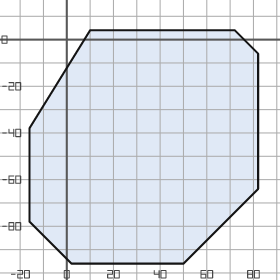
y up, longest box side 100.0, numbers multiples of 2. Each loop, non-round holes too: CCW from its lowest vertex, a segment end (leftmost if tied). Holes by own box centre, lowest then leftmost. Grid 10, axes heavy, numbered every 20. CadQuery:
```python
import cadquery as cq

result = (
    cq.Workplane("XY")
    .moveTo(2.0, -96.0)
    .lineTo(50.0, -96.0)
    .lineTo(82.0, -64.0)
    .lineTo(82.0, -6.0)
    .lineTo(72.0, 4.0)
    .lineTo(10.0, 4.0)
    .lineTo(-16.0, -38.0)
    .lineTo(-16.0, -78.0)
    .close()
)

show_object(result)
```